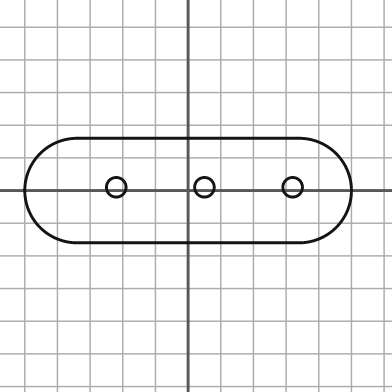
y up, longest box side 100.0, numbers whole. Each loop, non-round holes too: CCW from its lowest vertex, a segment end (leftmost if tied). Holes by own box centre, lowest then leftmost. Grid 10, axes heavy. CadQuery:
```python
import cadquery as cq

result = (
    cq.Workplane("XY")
    .moveTo(-34.0, -16.0)
    .lineTo(34.0, -16.0)
    .threePointArc((50.0, 0.0), (34.0, 16.0))
    .lineTo(-34.0, 16.0)
    .threePointArc((-50.0, 0.0), (-34.0, -16.0))
    .close()
    .moveTo(-22.0, 1.0)
    .circle(3.0)
    .moveTo(5.0, 1.0)
    .circle(3.0)
    .moveTo(32.0, 1.0)
    .circle(3.0)
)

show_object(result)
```